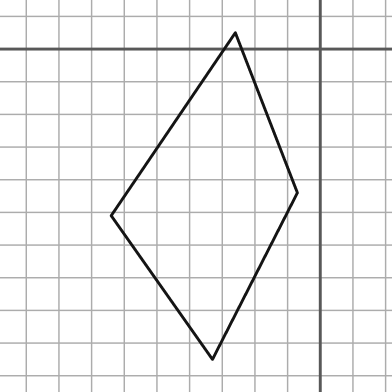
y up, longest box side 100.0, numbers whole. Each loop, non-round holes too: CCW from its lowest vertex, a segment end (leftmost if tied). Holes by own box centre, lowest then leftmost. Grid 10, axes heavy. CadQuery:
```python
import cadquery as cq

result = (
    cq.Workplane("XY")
    .moveTo(-33.0, -95.0)
    .lineTo(-7.0, -44.0)
    .lineTo(-26.0, 5.0)
    .lineTo(-64.0, -51.0)
    .close()
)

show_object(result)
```